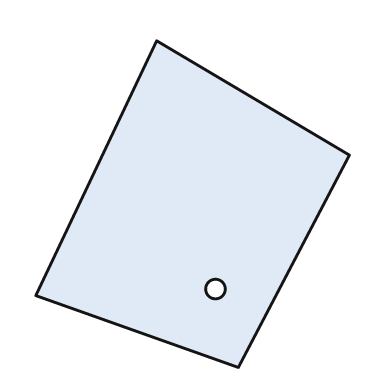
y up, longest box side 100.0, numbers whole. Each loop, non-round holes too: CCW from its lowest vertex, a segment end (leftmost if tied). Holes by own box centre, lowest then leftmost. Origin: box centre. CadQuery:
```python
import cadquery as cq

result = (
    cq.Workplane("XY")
    .moveTo(14.0, -50.0)
    .lineTo(48.0, 15.0)
    .lineTo(-11.0, 50.0)
    .lineTo(-48.0, -28.0)
    .close()
    .moveTo(7.0, -26.0)
    .circle(3.0)
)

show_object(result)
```